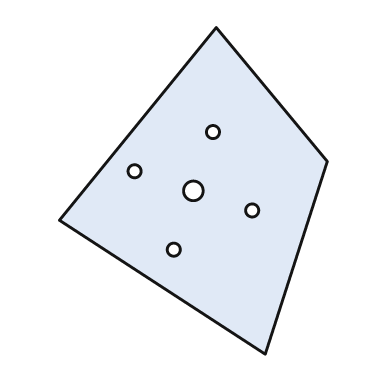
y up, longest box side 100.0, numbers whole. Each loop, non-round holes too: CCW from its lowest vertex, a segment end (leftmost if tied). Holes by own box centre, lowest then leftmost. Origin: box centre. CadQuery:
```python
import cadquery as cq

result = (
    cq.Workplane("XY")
    .moveTo(22.0, -50.0)
    .lineTo(41.0, 9.0)
    .lineTo(7.0, 50.0)
    .lineTo(-41.0, -9.0)
    .close()
    .moveTo(-6.0, -18.0)
    .circle(2.0)
    .moveTo(18.0, -6.0)
    .circle(2.0)
    .moveTo(0.0, 0.0)
    .circle(3.0)
    .moveTo(-18.0, 6.0)
    .circle(2.0)
    .moveTo(6.0, 18.0)
    .circle(2.0)
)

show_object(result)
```